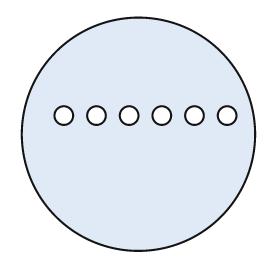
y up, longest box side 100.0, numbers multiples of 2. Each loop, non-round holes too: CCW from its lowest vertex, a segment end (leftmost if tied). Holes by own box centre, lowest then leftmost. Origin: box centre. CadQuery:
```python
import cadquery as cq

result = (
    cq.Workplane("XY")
    .moveTo(0.0, 0.0)
    .circle(50.0)
    .moveTo(-32.0, 8.0)
    .circle(4.0)
    .moveTo(-18.0, 8.0)
    .circle(4.0)
    .moveTo(-4.0, 8.0)
    .circle(4.0)
    .moveTo(10.0, 8.0)
    .circle(4.0)
    .moveTo(24.0, 8.0)
    .circle(4.0)
    .moveTo(38.0, 8.0)
    .circle(4.0)
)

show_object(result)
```